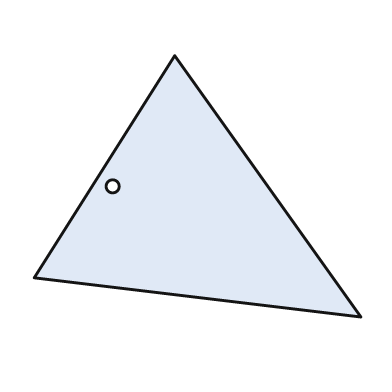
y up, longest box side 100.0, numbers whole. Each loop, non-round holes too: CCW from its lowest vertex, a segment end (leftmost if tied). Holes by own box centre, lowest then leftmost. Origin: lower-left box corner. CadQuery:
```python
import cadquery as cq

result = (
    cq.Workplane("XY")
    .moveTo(100.0, 0.0)
    .lineTo(43.0, 80.0)
    .lineTo(0.0, 12.0)
    .close()
    .moveTo(24.0, 40.0)
    .circle(2.0)
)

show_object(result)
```